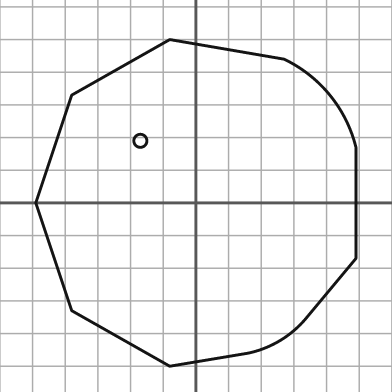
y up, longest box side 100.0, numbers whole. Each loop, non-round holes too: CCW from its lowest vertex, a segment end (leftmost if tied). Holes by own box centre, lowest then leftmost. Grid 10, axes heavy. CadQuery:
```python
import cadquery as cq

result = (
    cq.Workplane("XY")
    .moveTo(-8.0, -50.0)
    .lineTo(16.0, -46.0)
    .threePointArc((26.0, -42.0), (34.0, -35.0))
    .lineTo(49.0, -17.0)
    .lineTo(49.0, 17.0)
    .threePointArc((41.0, 33.0), (27.0, 44.0))
    .lineTo(-8.0, 50.0)
    .lineTo(-38.0, 33.0)
    .lineTo(-49.0, 0.0)
    .lineTo(-38.0, -33.0)
    .close()
    .moveTo(-17.0, 19.0)
    .circle(2.0)
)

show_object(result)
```